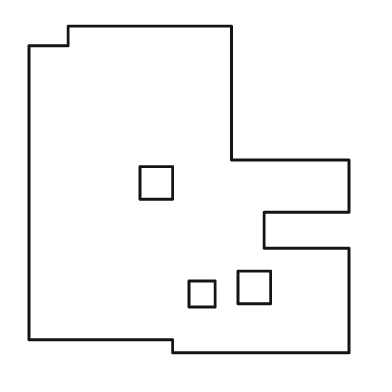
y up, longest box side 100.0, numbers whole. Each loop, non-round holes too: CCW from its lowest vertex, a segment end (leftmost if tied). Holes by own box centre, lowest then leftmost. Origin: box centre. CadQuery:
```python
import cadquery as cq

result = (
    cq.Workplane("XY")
    .moveTo(-5.0, -50.0)
    .lineTo(49.0, -50.0)
    .lineTo(49.0, -18.0)
    .lineTo(23.0, -18.0)
    .lineTo(23.0, -7.0)
    .lineTo(49.0, -7.0)
    .lineTo(49.0, 9.0)
    .lineTo(13.0, 9.0)
    .lineTo(13.0, 50.0)
    .lineTo(-37.0, 50.0)
    .lineTo(-37.0, 44.0)
    .lineTo(-49.0, 44.0)
    .lineTo(-49.0, -46.0)
    .lineTo(-5.0, -46.0)
    .close()
    .moveTo(0.0, -36.0)
    .lineTo(8.0, -36.0)
    .lineTo(8.0, -28.0)
    .lineTo(0.0, -28.0)
    .close()
    .moveTo(15.0, -35.0)
    .lineTo(25.0, -35.0)
    .lineTo(25.0, -25.0)
    .lineTo(15.0, -25.0)
    .close()
    .moveTo(-15.0, -3.0)
    .lineTo(-5.0, -3.0)
    .lineTo(-5.0, 7.0)
    .lineTo(-15.0, 7.0)
    .close()
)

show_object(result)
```